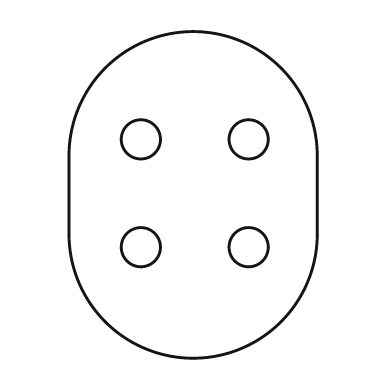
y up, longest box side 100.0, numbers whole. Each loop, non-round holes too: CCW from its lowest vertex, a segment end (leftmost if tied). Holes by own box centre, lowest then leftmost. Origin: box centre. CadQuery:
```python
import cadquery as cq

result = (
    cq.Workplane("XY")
    .moveTo(-38.0, -12.0)
    .threePointArc((0.0, -50.0), (38.0, -12.0))
    .lineTo(38.0, 12.0)
    .threePointArc((0.0, 50.0), (-38.0, 12.0))
    .close()
    .moveTo(-16.0, -16.0)
    .circle(6.0)
    .moveTo(17.0, -16.0)
    .circle(6.0)
    .moveTo(-16.0, 17.0)
    .circle(6.0)
    .moveTo(17.0, 17.0)
    .circle(6.0)
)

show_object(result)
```